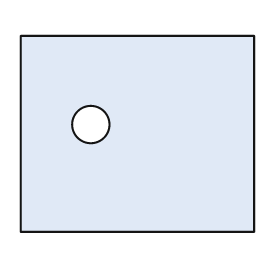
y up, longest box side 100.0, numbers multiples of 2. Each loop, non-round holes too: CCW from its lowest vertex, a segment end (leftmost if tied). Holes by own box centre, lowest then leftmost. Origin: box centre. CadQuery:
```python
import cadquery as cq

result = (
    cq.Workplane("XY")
    .moveTo(-50.0, -42.0)
    .lineTo(50.0, -42.0)
    .lineTo(50.0, 42.0)
    .lineTo(-50.0, 42.0)
    .close()
    .moveTo(-20.0, 4.0)
    .circle(8.0)
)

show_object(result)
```